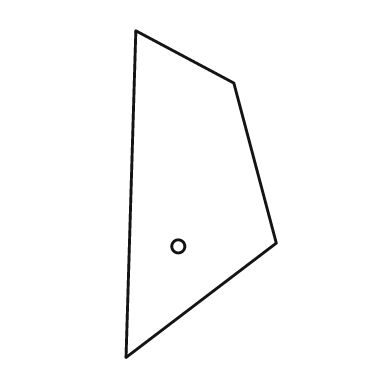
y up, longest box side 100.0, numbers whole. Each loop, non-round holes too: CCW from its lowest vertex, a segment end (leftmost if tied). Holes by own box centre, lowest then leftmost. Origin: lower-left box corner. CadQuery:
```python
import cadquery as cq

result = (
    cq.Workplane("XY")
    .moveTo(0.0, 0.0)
    .lineTo(46.0, 35.0)
    .lineTo(33.0, 84.0)
    .lineTo(3.0, 100.0)
    .close()
    .moveTo(16.0, 34.0)
    .circle(2.0)
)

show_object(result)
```